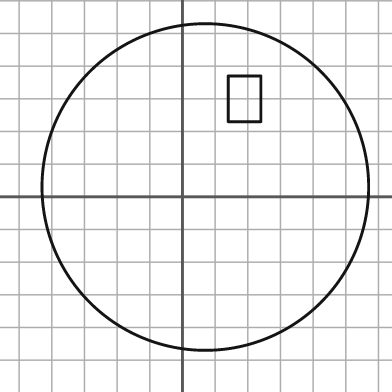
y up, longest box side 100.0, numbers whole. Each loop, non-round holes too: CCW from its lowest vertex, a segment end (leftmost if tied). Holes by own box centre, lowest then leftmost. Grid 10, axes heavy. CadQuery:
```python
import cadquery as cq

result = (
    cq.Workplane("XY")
    .moveTo(7.0, 3.0)
    .circle(50.0)
    .moveTo(14.0, 23.0)
    .lineTo(24.0, 23.0)
    .lineTo(24.0, 37.0)
    .lineTo(14.0, 37.0)
    .close()
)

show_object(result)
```